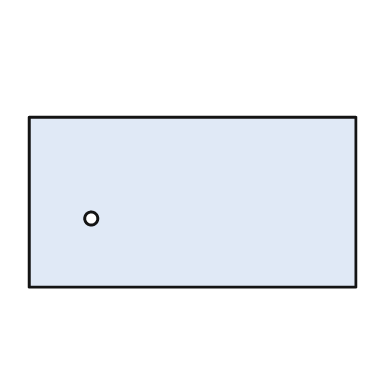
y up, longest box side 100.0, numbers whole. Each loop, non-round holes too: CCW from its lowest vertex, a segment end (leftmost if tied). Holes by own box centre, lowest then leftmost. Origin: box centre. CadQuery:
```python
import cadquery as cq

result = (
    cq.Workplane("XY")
    .moveTo(-50.0, -26.0)
    .lineTo(50.0, -26.0)
    .lineTo(50.0, 26.0)
    .lineTo(-50.0, 26.0)
    .close()
    .moveTo(-31.0, -5.0)
    .circle(2.0)
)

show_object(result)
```